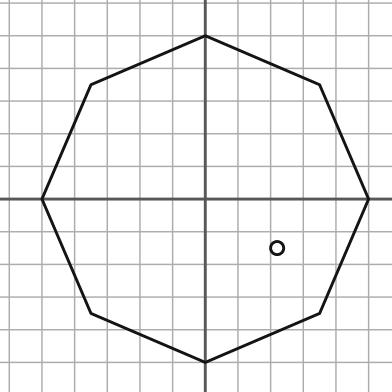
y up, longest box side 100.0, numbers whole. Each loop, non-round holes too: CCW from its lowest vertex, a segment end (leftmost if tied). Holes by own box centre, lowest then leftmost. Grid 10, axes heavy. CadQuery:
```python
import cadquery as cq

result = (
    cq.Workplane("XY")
    .moveTo(0.0, -50.0)
    .lineTo(35.0, -35.0)
    .lineTo(50.0, 0.0)
    .lineTo(35.0, 35.0)
    .lineTo(0.0, 50.0)
    .lineTo(-35.0, 35.0)
    .lineTo(-50.0, 0.0)
    .lineTo(-35.0, -35.0)
    .close()
    .moveTo(22.0, -15.0)
    .circle(2.0)
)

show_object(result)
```